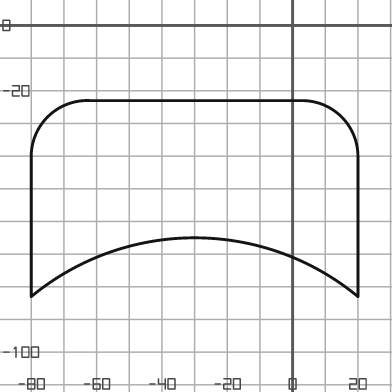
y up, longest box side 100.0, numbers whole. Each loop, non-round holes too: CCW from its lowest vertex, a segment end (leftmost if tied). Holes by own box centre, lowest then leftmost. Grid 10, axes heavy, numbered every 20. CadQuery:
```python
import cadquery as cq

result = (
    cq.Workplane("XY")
    .moveTo(-80.0, -83.0)
    .threePointArc((-30.0, -65.0), (20.0, -83.0))
    .lineTo(20.0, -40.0)
    .threePointArc((15.0, -28.0), (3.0, -23.0))
    .lineTo(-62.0, -23.0)
    .threePointArc((-75.0, -28.0), (-80.0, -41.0))
    .close()
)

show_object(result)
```